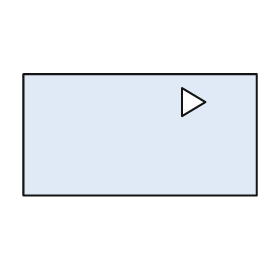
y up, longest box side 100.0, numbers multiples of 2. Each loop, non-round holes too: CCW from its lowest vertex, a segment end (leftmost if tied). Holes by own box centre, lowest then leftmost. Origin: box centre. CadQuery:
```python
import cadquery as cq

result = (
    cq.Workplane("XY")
    .moveTo(-50.0, -26.0)
    .lineTo(50.0, -26.0)
    .lineTo(50.0, 26.0)
    .lineTo(-50.0, 26.0)
    .close()
    .moveTo(18.0, 8.0)
    .lineTo(28.0, 14.0)
    .lineTo(18.0, 20.0)
    .close()
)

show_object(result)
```